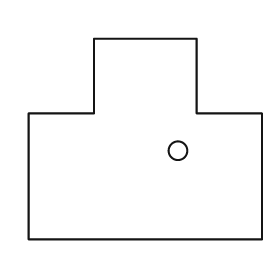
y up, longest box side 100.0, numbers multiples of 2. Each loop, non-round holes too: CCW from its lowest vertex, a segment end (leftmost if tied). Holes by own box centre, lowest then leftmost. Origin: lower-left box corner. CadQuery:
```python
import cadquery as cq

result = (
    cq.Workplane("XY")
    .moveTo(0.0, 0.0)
    .lineTo(100.0, 0.0)
    .lineTo(100.0, 54.0)
    .lineTo(72.0, 54.0)
    .lineTo(72.0, 86.0)
    .lineTo(28.0, 86.0)
    .lineTo(28.0, 54.0)
    .lineTo(0.0, 54.0)
    .close()
    .moveTo(64.0, 38.0)
    .circle(4.0)
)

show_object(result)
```